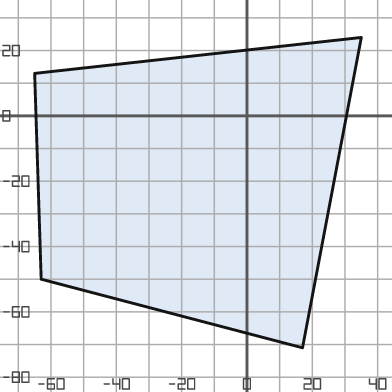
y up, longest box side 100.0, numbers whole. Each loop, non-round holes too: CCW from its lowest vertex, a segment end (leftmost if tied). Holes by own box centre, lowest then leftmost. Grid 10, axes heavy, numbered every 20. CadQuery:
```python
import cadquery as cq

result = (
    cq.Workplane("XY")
    .moveTo(17.0, -71.0)
    .lineTo(35.0, 24.0)
    .lineTo(-65.0, 13.0)
    .lineTo(-63.0, -50.0)
    .close()
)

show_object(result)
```